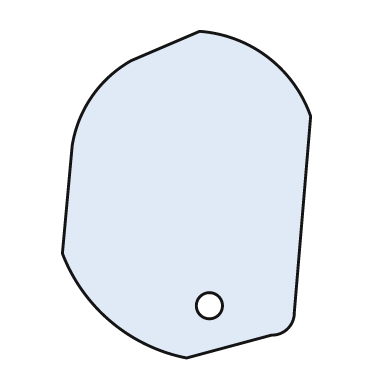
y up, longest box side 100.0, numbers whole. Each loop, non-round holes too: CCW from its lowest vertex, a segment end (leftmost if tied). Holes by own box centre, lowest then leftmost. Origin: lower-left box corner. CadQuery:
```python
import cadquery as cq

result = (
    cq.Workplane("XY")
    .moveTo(38.0, 0.0)
    .lineTo(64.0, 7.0)
    .threePointArc((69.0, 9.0), (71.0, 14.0))
    .lineTo(76.0, 74.0)
    .threePointArc((63.0, 92.0), (42.0, 100.0))
    .lineTo(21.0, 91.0)
    .threePointArc((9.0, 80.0), (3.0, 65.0))
    .lineTo(0.0, 32.0)
    .threePointArc((15.0, 11.0), (38.0, 0.0))
    .close()
    .moveTo(45.0, 16.0)
    .circle(4.0)
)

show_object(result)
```